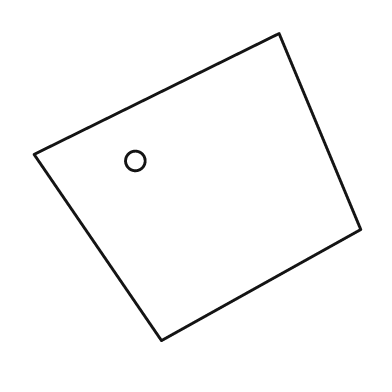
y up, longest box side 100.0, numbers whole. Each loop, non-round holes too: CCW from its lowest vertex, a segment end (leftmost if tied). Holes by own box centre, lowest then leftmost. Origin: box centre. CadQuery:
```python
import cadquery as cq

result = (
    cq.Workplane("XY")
    .moveTo(-11.0, -47.0)
    .lineTo(50.0, -13.0)
    .lineTo(25.0, 47.0)
    .lineTo(-50.0, 10.0)
    .close()
    .moveTo(-19.0, 8.0)
    .circle(3.0)
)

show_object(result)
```